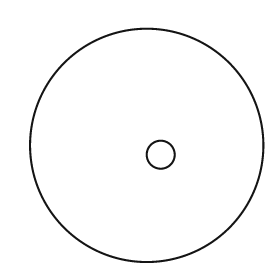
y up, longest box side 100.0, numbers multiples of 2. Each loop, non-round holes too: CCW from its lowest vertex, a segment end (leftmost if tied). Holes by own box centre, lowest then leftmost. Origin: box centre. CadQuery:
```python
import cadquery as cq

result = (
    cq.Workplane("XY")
    .moveTo(0.0, 0.0)
    .circle(50.0)
    .moveTo(6.0, -4.0)
    .circle(6.0)
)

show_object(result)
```